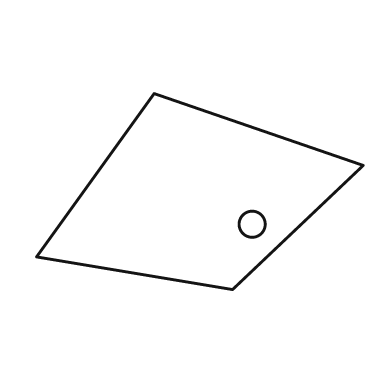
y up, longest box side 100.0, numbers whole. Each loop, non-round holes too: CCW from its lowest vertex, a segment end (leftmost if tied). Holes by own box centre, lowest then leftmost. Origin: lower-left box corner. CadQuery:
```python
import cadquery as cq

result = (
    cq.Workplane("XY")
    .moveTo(60.0, 0.0)
    .lineTo(100.0, 38.0)
    .lineTo(36.0, 60.0)
    .lineTo(0.0, 10.0)
    .close()
    .moveTo(66.0, 20.0)
    .circle(4.0)
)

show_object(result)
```